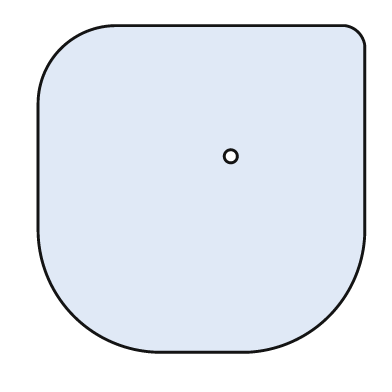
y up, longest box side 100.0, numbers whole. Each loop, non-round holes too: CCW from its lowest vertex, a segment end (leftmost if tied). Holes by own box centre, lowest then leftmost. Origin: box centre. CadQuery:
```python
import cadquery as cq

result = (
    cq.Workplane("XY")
    .moveTo(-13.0, -50.0)
    .lineTo(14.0, -50.0)
    .threePointArc((39.0, -39.0), (50.0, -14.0))
    .lineTo(50.0, 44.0)
    .threePointArc((48.0, 48.0), (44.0, 50.0))
    .lineTo(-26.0, 50.0)
    .threePointArc((-43.0, 43.0), (-50.0, 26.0))
    .lineTo(-50.0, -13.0)
    .threePointArc((-39.0, -39.0), (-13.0, -50.0))
    .close()
    .moveTo(9.0, 10.0)
    .circle(2.0)
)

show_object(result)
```